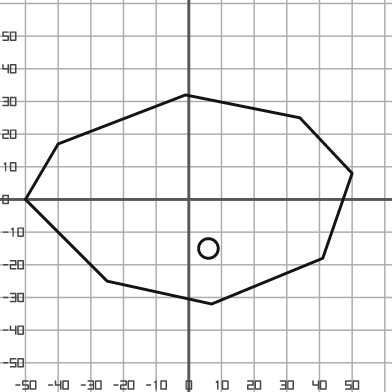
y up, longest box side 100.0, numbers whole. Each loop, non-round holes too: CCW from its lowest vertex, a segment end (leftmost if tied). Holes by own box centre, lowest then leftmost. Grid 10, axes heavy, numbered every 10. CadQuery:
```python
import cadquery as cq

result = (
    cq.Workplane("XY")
    .moveTo(7.0, -32.0)
    .lineTo(41.0, -18.0)
    .lineTo(50.0, 8.0)
    .lineTo(34.0, 25.0)
    .lineTo(-1.0, 32.0)
    .lineTo(-40.0, 17.0)
    .lineTo(-50.0, 0.0)
    .lineTo(-25.0, -25.0)
    .close()
    .moveTo(6.0, -15.0)
    .circle(3.0)
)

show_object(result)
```